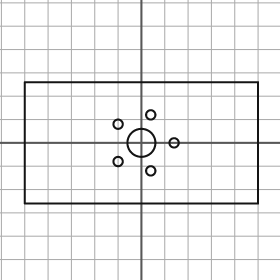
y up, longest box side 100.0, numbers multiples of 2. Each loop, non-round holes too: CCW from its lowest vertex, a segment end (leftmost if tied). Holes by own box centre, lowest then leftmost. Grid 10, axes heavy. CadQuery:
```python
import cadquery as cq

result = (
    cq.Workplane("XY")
    .moveTo(-50.0, -26.0)
    .lineTo(50.0, -26.0)
    .lineTo(50.0, 26.0)
    .lineTo(-50.0, 26.0)
    .close()
    .moveTo(4.0, -12.0)
    .circle(2.0)
    .moveTo(-10.0, -8.0)
    .circle(2.0)
    .moveTo(0.0, 0.0)
    .circle(6.0)
    .moveTo(14.0, 0.0)
    .circle(2.0)
    .moveTo(-10.0, 8.0)
    .circle(2.0)
    .moveTo(4.0, 12.0)
    .circle(2.0)
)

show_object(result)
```